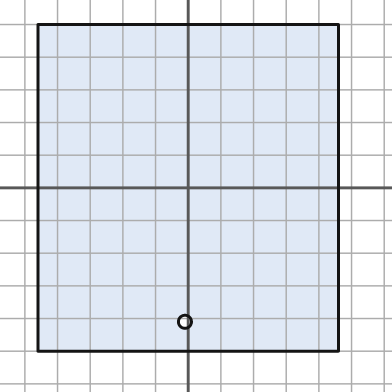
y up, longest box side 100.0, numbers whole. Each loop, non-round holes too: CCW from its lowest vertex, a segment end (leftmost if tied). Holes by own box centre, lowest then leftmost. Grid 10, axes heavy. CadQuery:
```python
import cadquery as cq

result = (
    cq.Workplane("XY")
    .moveTo(-46.0, -50.0)
    .lineTo(46.0, -50.0)
    .lineTo(46.0, 50.0)
    .lineTo(-46.0, 50.0)
    .close()
    .moveTo(-1.0, -41.0)
    .circle(2.0)
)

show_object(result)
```